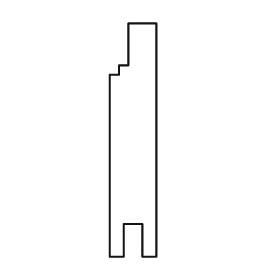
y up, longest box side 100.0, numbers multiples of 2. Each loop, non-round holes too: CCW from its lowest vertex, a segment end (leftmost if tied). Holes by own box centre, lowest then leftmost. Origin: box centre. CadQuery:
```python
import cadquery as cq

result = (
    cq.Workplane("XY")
    .moveTo(-10.0, -50.0)
    .lineTo(-4.0, -50.0)
    .lineTo(-4.0, -36.0)
    .lineTo(4.0, -36.0)
    .lineTo(4.0, -50.0)
    .lineTo(10.0, -50.0)
    .lineTo(10.0, 50.0)
    .lineTo(-2.0, 50.0)
    .lineTo(-2.0, 32.0)
    .lineTo(-6.0, 32.0)
    .lineTo(-6.0, 28.0)
    .lineTo(-10.0, 28.0)
    .close()
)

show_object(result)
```